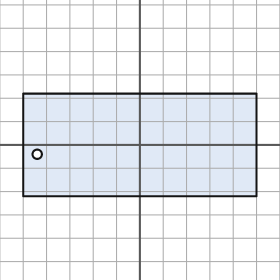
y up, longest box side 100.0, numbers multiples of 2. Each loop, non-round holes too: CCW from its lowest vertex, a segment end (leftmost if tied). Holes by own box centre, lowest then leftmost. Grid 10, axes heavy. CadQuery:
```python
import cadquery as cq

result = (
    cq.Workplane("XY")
    .moveTo(-50.0, -22.0)
    .lineTo(50.0, -22.0)
    .lineTo(50.0, 22.0)
    .lineTo(-50.0, 22.0)
    .close()
    .moveTo(-44.0, -4.0)
    .circle(2.0)
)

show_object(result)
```